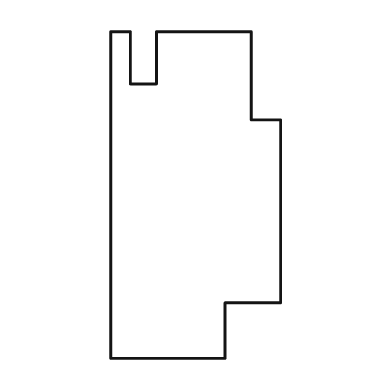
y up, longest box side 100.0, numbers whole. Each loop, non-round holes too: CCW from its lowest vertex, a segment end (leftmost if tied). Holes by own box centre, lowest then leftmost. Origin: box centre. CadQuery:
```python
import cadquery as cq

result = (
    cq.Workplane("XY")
    .moveTo(-26.0, -50.0)
    .lineTo(9.0, -50.0)
    .lineTo(9.0, -33.0)
    .lineTo(26.0, -33.0)
    .lineTo(26.0, 23.0)
    .lineTo(17.0, 23.0)
    .lineTo(17.0, 50.0)
    .lineTo(-12.0, 50.0)
    .lineTo(-12.0, 34.0)
    .lineTo(-20.0, 34.0)
    .lineTo(-20.0, 50.0)
    .lineTo(-26.0, 50.0)
    .close()
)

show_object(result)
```